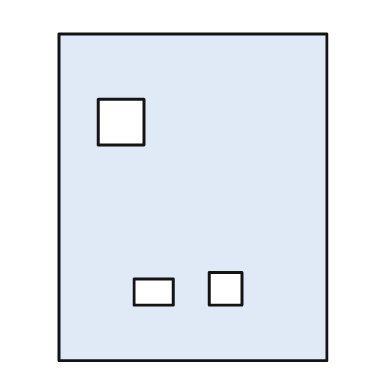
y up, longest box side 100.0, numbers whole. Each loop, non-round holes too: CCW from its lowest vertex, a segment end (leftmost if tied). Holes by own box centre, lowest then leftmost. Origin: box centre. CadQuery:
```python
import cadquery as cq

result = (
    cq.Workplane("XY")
    .moveTo(-41.0, -50.0)
    .lineTo(41.0, -50.0)
    .lineTo(41.0, 50.0)
    .lineTo(-41.0, 50.0)
    .close()
    .moveTo(-18.0, -33.0)
    .lineTo(-6.0, -33.0)
    .lineTo(-6.0, -25.0)
    .lineTo(-18.0, -25.0)
    .close()
    .moveTo(5.0, -33.0)
    .lineTo(15.0, -33.0)
    .lineTo(15.0, -23.0)
    .lineTo(5.0, -23.0)
    .close()
    .moveTo(-29.0, 16.0)
    .lineTo(-15.0, 16.0)
    .lineTo(-15.0, 30.0)
    .lineTo(-29.0, 30.0)
    .close()
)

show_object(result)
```